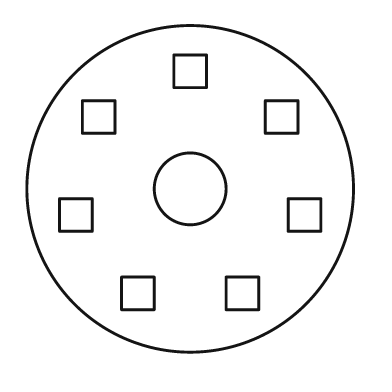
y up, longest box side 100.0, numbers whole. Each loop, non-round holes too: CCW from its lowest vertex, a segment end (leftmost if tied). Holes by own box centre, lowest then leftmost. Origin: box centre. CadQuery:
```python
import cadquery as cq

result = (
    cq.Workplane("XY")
    .moveTo(0.0, 0.0)
    .circle(50.0)
    .moveTo(-21.0, -37.0)
    .lineTo(-11.0, -37.0)
    .lineTo(-11.0, -27.0)
    .lineTo(-21.0, -27.0)
    .close()
    .moveTo(11.0, -37.0)
    .lineTo(21.0, -37.0)
    .lineTo(21.0, -27.0)
    .lineTo(11.0, -27.0)
    .close()
    .moveTo(-40.0, -13.0)
    .lineTo(-30.0, -13.0)
    .lineTo(-30.0, -3.0)
    .lineTo(-40.0, -3.0)
    .close()
    .moveTo(30.0, -13.0)
    .lineTo(40.0, -13.0)
    .lineTo(40.0, -3.0)
    .lineTo(30.0, -3.0)
    .close()
    .moveTo(0.0, 0.0)
    .circle(11.0)
    .moveTo(-33.0, 17.0)
    .lineTo(-23.0, 17.0)
    .lineTo(-23.0, 27.0)
    .lineTo(-33.0, 27.0)
    .close()
    .moveTo(23.0, 17.0)
    .lineTo(33.0, 17.0)
    .lineTo(33.0, 27.0)
    .lineTo(23.0, 27.0)
    .close()
    .moveTo(-5.0, 31.0)
    .lineTo(5.0, 31.0)
    .lineTo(5.0, 41.0)
    .lineTo(-5.0, 41.0)
    .close()
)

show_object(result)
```